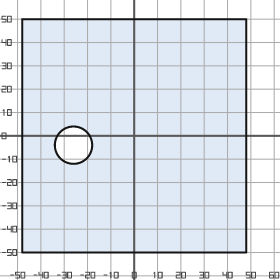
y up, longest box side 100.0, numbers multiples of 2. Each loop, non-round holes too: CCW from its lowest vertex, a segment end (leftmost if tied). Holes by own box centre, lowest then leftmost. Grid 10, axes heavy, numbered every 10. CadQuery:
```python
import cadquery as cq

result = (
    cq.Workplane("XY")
    .moveTo(-48.0, -50.0)
    .lineTo(48.0, -50.0)
    .lineTo(48.0, 50.0)
    .lineTo(-48.0, 50.0)
    .close()
    .moveTo(-26.0, -4.0)
    .circle(8.0)
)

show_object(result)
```